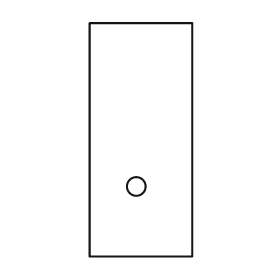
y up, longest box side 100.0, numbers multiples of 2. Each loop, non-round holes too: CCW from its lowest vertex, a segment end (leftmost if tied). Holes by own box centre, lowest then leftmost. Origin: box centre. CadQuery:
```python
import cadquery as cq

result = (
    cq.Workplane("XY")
    .moveTo(-22.0, -50.0)
    .lineTo(22.0, -50.0)
    .lineTo(22.0, 50.0)
    .lineTo(-22.0, 50.0)
    .close()
    .moveTo(-2.0, -20.0)
    .circle(4.0)
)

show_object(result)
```